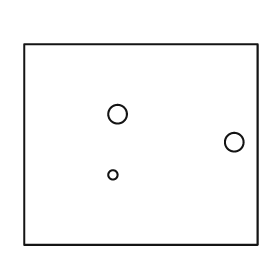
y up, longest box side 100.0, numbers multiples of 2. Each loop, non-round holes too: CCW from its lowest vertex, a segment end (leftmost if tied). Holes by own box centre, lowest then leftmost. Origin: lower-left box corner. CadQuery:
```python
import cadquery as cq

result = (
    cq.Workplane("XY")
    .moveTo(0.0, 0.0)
    .lineTo(100.0, 0.0)
    .lineTo(100.0, 86.0)
    .lineTo(0.0, 86.0)
    .close()
    .moveTo(38.0, 30.0)
    .circle(2.0)
    .moveTo(90.0, 44.0)
    .circle(4.0)
    .moveTo(40.0, 56.0)
    .circle(4.0)
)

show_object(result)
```